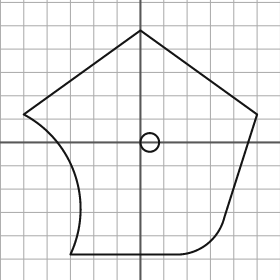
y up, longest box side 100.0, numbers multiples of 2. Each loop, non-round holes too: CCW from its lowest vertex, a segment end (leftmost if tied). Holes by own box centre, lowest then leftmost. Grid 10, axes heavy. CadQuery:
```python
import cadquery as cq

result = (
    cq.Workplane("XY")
    .moveTo(-30.0, -48.0)
    .lineTo(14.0, -48.0)
    .threePointArc((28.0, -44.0), (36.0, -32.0))
    .lineTo(50.0, 12.0)
    .lineTo(0.0, 48.0)
    .lineTo(-50.0, 12.0)
    .threePointArc((-28.0, -14.0), (-30.0, -48.0))
    .close()
    .moveTo(4.0, 0.0)
    .circle(4.0)
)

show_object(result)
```